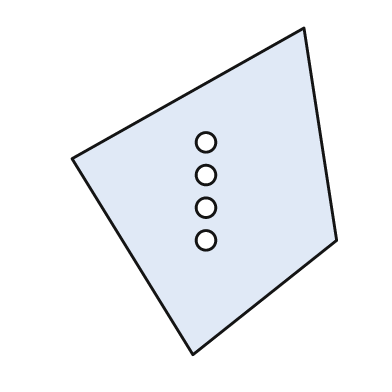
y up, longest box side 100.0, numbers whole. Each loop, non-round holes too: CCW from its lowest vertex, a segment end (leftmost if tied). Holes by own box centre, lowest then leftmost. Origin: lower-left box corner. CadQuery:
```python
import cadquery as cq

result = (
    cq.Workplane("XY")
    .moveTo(37.0, 0.0)
    .lineTo(81.0, 35.0)
    .lineTo(71.0, 100.0)
    .lineTo(0.0, 60.0)
    .close()
    .moveTo(41.0, 35.0)
    .circle(3.0)
    .moveTo(41.0, 45.0)
    .circle(3.0)
    .moveTo(41.0, 55.0)
    .circle(3.0)
    .moveTo(41.0, 65.0)
    .circle(3.0)
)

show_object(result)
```